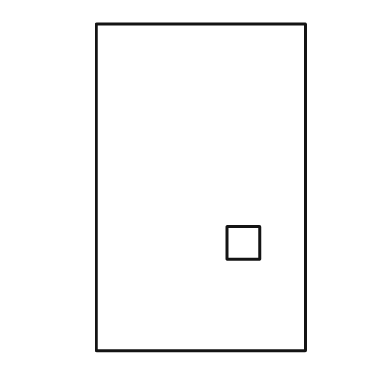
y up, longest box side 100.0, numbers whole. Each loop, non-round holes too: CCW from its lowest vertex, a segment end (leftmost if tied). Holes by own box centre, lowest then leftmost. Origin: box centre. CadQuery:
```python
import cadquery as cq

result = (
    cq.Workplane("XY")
    .moveTo(-32.0, -50.0)
    .lineTo(32.0, -50.0)
    .lineTo(32.0, 50.0)
    .lineTo(-32.0, 50.0)
    .close()
    .moveTo(8.0, -22.0)
    .lineTo(18.0, -22.0)
    .lineTo(18.0, -12.0)
    .lineTo(8.0, -12.0)
    .close()
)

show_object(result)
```